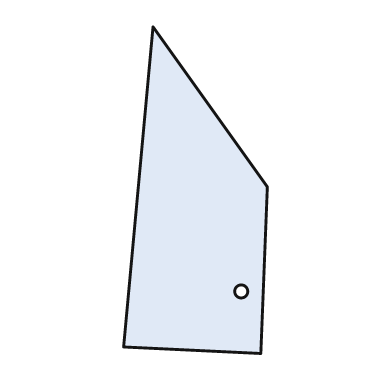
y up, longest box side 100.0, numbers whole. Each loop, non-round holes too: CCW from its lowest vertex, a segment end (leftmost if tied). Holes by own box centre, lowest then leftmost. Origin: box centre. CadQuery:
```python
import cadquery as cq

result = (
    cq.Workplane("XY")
    .moveTo(20.0, -50.0)
    .lineTo(22.0, 1.0)
    .lineTo(-13.0, 50.0)
    .lineTo(-22.0, -48.0)
    .close()
    .moveTo(14.0, -31.0)
    .circle(2.0)
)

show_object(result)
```